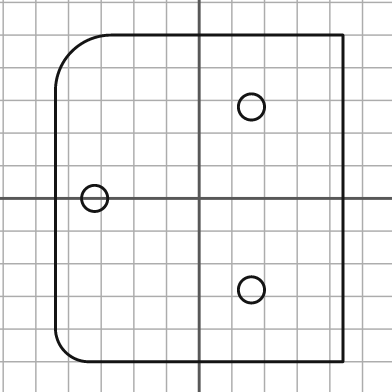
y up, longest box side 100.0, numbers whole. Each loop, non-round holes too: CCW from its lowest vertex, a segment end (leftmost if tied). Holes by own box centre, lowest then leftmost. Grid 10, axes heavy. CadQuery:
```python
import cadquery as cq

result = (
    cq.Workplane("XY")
    .moveTo(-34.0, -50.0)
    .lineTo(44.0, -50.0)
    .lineTo(44.0, 50.0)
    .lineTo(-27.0, 50.0)
    .threePointArc((-39.0, 45.0), (-44.0, 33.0))
    .lineTo(-44.0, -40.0)
    .threePointArc((-41.0, -47.0), (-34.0, -50.0))
    .close()
    .moveTo(16.0, -28.0)
    .circle(4.0)
    .moveTo(-32.0, 0.0)
    .circle(4.0)
    .moveTo(16.0, 28.0)
    .circle(4.0)
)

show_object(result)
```